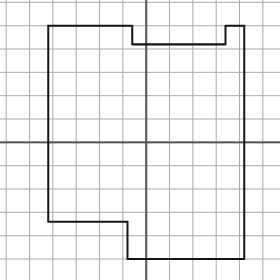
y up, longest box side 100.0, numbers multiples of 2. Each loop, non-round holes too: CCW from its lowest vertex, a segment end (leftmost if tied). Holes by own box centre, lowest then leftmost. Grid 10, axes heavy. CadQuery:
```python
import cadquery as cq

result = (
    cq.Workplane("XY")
    .moveTo(-8.0, -50.0)
    .lineTo(42.0, -50.0)
    .lineTo(42.0, 50.0)
    .lineTo(34.0, 50.0)
    .lineTo(34.0, 42.0)
    .lineTo(-6.0, 42.0)
    .lineTo(-6.0, 50.0)
    .lineTo(-42.0, 50.0)
    .lineTo(-42.0, -34.0)
    .lineTo(-8.0, -34.0)
    .close()
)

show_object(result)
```